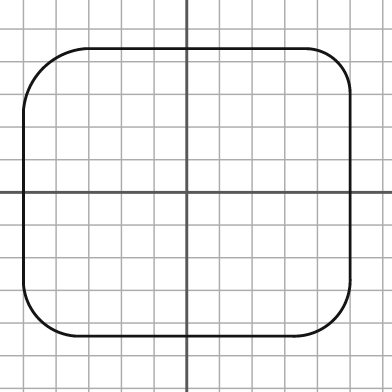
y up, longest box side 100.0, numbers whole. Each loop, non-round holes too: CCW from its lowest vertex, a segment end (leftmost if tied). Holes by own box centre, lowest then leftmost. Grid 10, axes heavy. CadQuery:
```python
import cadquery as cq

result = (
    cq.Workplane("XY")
    .moveTo(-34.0, -44.0)
    .lineTo(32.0, -44.0)
    .threePointArc((45.0, -39.0), (50.0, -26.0))
    .lineTo(50.0, 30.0)
    .threePointArc((46.0, 40.0), (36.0, 44.0))
    .lineTo(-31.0, 44.0)
    .threePointArc((-44.0, 38.0), (-50.0, 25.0))
    .lineTo(-50.0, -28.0)
    .threePointArc((-45.0, -39.0), (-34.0, -44.0))
    .close()
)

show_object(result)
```